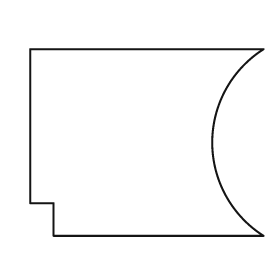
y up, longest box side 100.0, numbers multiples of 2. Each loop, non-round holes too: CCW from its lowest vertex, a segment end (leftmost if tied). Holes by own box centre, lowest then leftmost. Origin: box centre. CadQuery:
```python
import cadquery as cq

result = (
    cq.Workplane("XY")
    .moveTo(-40.0, -40.0)
    .lineTo(50.0, -40.0)
    .threePointArc((28.0, 0.0), (50.0, 40.0))
    .lineTo(-50.0, 40.0)
    .lineTo(-50.0, -26.0)
    .lineTo(-40.0, -26.0)
    .close()
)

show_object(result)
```